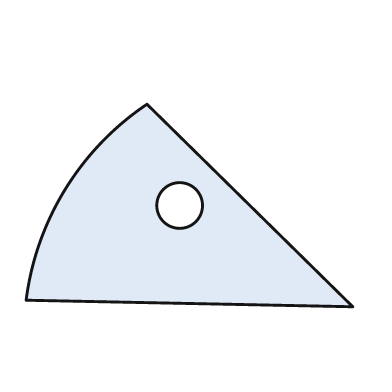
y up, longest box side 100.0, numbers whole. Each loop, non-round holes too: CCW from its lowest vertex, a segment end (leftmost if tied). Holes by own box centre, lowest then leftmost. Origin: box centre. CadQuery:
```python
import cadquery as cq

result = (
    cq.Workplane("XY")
    .moveTo(50.0, -31.0)
    .lineTo(-13.0, 31.0)
    .threePointArc((-38.0, 5.0), (-50.0, -29.0))
    .close()
    .moveTo(-3.0, 0.0)
    .circle(7.0)
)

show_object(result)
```